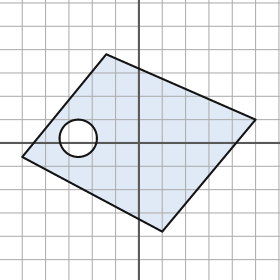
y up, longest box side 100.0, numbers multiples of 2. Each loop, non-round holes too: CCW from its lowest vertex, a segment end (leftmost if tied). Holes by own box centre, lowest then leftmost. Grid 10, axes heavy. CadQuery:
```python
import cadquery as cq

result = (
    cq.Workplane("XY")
    .moveTo(10.0, -38.0)
    .lineTo(50.0, 10.0)
    .lineTo(-14.0, 38.0)
    .lineTo(-50.0, -6.0)
    .close()
    .moveTo(-26.0, 2.0)
    .circle(8.0)
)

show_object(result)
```